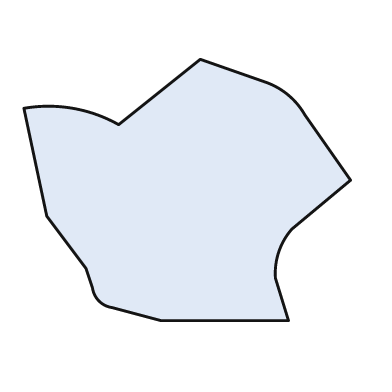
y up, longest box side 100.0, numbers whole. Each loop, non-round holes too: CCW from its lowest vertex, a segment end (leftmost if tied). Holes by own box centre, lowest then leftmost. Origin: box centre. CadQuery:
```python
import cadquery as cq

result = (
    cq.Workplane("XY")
    .moveTo(-8.0, -40.0)
    .lineTo(31.0, -40.0)
    .lineTo(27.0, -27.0)
    .threePointArc((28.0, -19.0), (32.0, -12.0))
    .lineTo(50.0, 3.0)
    .lineTo(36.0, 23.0)
    .threePointArc((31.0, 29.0), (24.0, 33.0))
    .lineTo(4.0, 40.0)
    .lineTo(-21.0, 20.0)
    .threePointArc((-35.0, 25.0), (-50.0, 25.0))
    .lineTo(-43.0, -8.0)
    .lineTo(-31.0, -24.0)
    .lineTo(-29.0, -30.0)
    .threePointArc((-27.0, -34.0), (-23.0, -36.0))
    .close()
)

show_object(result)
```